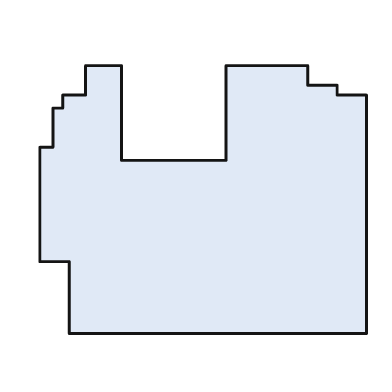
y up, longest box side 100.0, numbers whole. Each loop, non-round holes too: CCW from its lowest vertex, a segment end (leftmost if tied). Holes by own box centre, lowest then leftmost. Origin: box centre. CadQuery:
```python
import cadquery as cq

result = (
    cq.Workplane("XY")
    .moveTo(-41.0, -41.0)
    .lineTo(50.0, -41.0)
    .lineTo(50.0, 32.0)
    .lineTo(41.0, 32.0)
    .lineTo(41.0, 35.0)
    .lineTo(32.0, 35.0)
    .lineTo(32.0, 41.0)
    .lineTo(7.0, 41.0)
    .lineTo(7.0, 12.0)
    .lineTo(-25.0, 12.0)
    .lineTo(-25.0, 41.0)
    .lineTo(-36.0, 41.0)
    .lineTo(-36.0, 32.0)
    .lineTo(-43.0, 32.0)
    .lineTo(-43.0, 28.0)
    .lineTo(-46.0, 28.0)
    .lineTo(-46.0, 16.0)
    .lineTo(-50.0, 16.0)
    .lineTo(-50.0, -19.0)
    .lineTo(-41.0, -19.0)
    .close()
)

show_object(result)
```